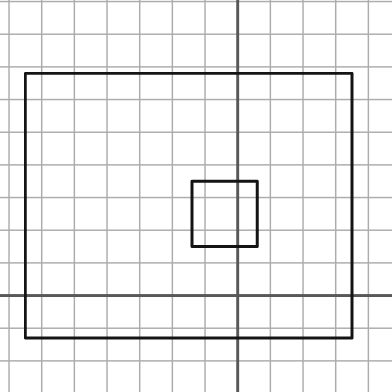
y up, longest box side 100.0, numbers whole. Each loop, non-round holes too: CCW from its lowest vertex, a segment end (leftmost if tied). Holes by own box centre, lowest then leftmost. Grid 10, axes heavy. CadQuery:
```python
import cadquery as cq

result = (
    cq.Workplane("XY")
    .moveTo(-65.0, -13.0)
    .lineTo(35.0, -13.0)
    .lineTo(35.0, 68.0)
    .lineTo(-65.0, 68.0)
    .close()
    .moveTo(-14.0, 15.0)
    .lineTo(6.0, 15.0)
    .lineTo(6.0, 35.0)
    .lineTo(-14.0, 35.0)
    .close()
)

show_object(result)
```